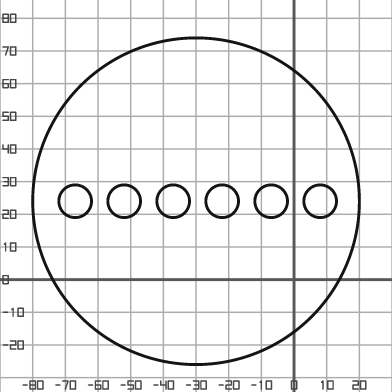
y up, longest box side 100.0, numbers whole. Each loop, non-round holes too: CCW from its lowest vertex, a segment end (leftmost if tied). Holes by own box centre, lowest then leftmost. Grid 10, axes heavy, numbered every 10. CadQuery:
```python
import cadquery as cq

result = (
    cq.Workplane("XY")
    .moveTo(-30.0, 24.0)
    .circle(50.0)
    .moveTo(-67.0, 24.0)
    .circle(5.0)
    .moveTo(-52.0, 24.0)
    .circle(5.0)
    .moveTo(-37.0, 24.0)
    .circle(5.0)
    .moveTo(-22.0, 24.0)
    .circle(5.0)
    .moveTo(-7.0, 24.0)
    .circle(5.0)
    .moveTo(8.0, 24.0)
    .circle(5.0)
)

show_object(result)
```